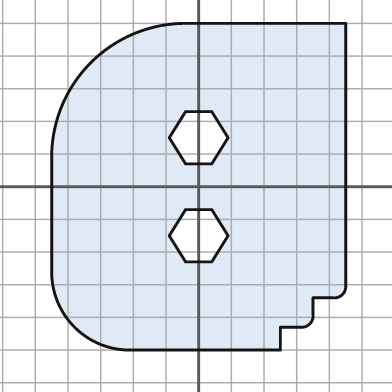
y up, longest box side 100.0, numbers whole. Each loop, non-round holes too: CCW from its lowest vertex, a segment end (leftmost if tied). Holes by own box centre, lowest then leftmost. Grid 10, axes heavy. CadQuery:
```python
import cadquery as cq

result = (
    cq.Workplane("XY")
    .moveTo(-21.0, -50.0)
    .lineTo(25.0, -50.0)
    .lineTo(25.0, -43.0)
    .lineTo(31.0, -43.0)
    .threePointArc((34.0, -42.0), (35.0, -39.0))
    .lineTo(35.0, -34.0)
    .lineTo(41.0, -34.0)
    .threePointArc((44.0, -33.0), (45.0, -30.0))
    .lineTo(45.0, 50.0)
    .lineTo(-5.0, 50.0)
    .threePointArc((-33.0, 38.0), (-45.0, 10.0))
    .lineTo(-45.0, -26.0)
    .threePointArc((-38.0, -43.0), (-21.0, -50.0))
    .close()
    .moveTo(-4.0, -23.0)
    .lineTo(4.0, -23.0)
    .lineTo(9.0, -15.0)
    .lineTo(4.0, -7.0)
    .lineTo(-4.0, -7.0)
    .lineTo(-9.0, -15.0)
    .close()
    .moveTo(-4.0, 7.0)
    .lineTo(4.0, 7.0)
    .lineTo(9.0, 15.0)
    .lineTo(4.0, 23.0)
    .lineTo(-4.0, 23.0)
    .lineTo(-9.0, 15.0)
    .close()
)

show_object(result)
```